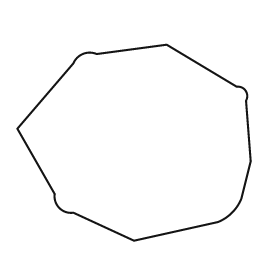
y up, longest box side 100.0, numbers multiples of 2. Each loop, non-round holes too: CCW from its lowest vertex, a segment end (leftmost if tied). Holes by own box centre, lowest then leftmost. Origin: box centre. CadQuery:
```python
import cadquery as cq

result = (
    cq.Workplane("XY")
    .moveTo(0.0, -42.0)
    .lineTo(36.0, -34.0)
    .threePointArc((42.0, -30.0), (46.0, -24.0))
    .lineTo(50.0, -8.0)
    .lineTo(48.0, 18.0)
    .threePointArc((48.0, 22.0), (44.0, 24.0))
    .lineTo(14.0, 42.0)
    .lineTo(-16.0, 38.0)
    .threePointArc((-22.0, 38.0), (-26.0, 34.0))
    .lineTo(-50.0, 6.0)
    .lineTo(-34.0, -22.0)
    .threePointArc((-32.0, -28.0), (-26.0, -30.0))
    .close()
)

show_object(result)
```